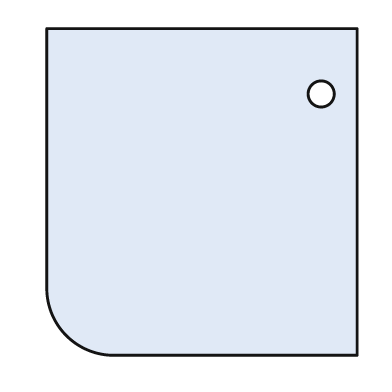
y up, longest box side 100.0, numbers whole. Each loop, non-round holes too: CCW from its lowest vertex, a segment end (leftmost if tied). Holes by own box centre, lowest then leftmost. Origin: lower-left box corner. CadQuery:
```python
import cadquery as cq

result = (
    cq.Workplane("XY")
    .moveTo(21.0, 0.0)
    .lineTo(95.0, 0.0)
    .lineTo(95.0, 100.0)
    .lineTo(0.0, 100.0)
    .lineTo(0.0, 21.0)
    .threePointArc((6.0, 6.0), (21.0, 0.0))
    .close()
    .moveTo(84.0, 80.0)
    .circle(4.0)
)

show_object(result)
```